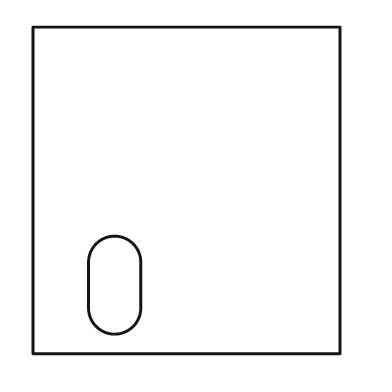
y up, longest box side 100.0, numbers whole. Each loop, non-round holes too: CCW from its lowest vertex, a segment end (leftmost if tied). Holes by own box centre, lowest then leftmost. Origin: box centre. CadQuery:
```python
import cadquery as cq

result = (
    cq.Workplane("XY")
    .moveTo(-47.0, -50.0)
    .lineTo(47.0, -50.0)
    .lineTo(47.0, 50.0)
    .lineTo(-47.0, 50.0)
    .close()
    .moveTo(-30.0, -36.0)
    .threePointArc((-22.0, -44.0), (-14.0, -36.0))
    .lineTo(-14.0, -22.0)
    .threePointArc((-22.0, -14.0), (-30.0, -22.0))
    .close()
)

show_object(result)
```